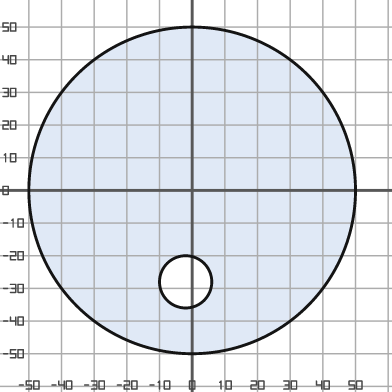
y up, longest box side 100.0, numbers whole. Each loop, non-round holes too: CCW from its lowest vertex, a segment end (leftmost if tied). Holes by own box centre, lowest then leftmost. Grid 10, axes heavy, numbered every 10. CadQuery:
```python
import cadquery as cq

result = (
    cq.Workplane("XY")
    .moveTo(0.0, 0.0)
    .circle(50.0)
    .moveTo(-2.0, -28.0)
    .circle(8.0)
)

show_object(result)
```